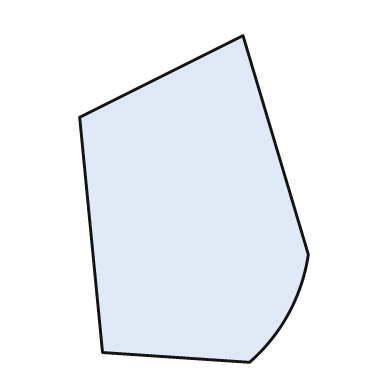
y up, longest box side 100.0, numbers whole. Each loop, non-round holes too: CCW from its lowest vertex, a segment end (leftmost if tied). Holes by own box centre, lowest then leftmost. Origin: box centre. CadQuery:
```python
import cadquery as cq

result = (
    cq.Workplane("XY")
    .moveTo(17.0, -50.0)
    .threePointArc((29.0, -35.0), (35.0, -17.0))
    .lineTo(15.0, 50.0)
    .lineTo(-35.0, 25.0)
    .lineTo(-28.0, -47.0)
    .close()
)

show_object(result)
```